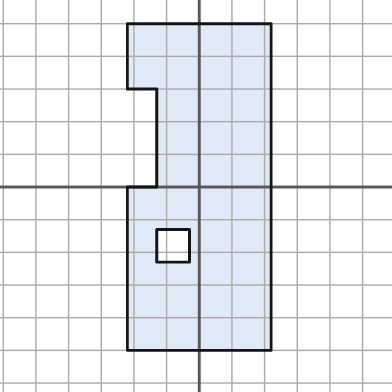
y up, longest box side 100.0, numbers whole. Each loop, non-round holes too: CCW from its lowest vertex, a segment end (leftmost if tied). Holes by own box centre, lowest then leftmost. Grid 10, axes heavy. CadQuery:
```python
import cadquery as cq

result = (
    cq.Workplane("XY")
    .moveTo(-22.0, -50.0)
    .lineTo(22.0, -50.0)
    .lineTo(22.0, 50.0)
    .lineTo(-22.0, 50.0)
    .lineTo(-22.0, 30.0)
    .lineTo(-13.0, 30.0)
    .lineTo(-13.0, 0.0)
    .lineTo(-22.0, 0.0)
    .close()
    .moveTo(-13.0, -23.0)
    .lineTo(-3.0, -23.0)
    .lineTo(-3.0, -13.0)
    .lineTo(-13.0, -13.0)
    .close()
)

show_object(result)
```